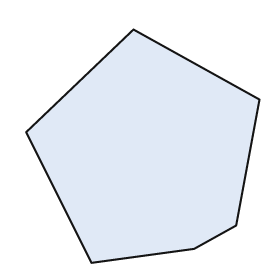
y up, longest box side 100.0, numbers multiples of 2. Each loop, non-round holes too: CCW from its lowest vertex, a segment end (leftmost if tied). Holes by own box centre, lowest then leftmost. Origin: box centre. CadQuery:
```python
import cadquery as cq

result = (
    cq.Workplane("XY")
    .moveTo(-22.0, -50.0)
    .lineTo(22.0, -44.0)
    .lineTo(40.0, -34.0)
    .lineTo(50.0, 20.0)
    .lineTo(-4.0, 50.0)
    .lineTo(-50.0, 6.0)
    .close()
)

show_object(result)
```